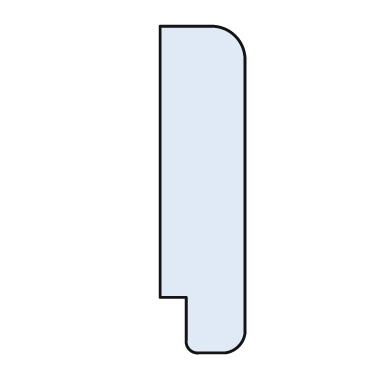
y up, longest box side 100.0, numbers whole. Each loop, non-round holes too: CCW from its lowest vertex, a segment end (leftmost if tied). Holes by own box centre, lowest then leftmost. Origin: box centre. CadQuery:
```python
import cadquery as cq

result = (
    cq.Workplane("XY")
    .moveTo(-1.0, -50.0)
    .lineTo(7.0, -50.0)
    .threePointArc((11.0, -48.0), (13.0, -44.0))
    .lineTo(13.0, 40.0)
    .threePointArc((10.0, 47.0), (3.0, 50.0))
    .lineTo(-13.0, 50.0)
    .lineTo(-13.0, -33.0)
    .lineTo(-5.0, -33.0)
    .lineTo(-5.0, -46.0)
    .threePointArc((-4.0, -49.0), (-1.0, -50.0))
    .close()
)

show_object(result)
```